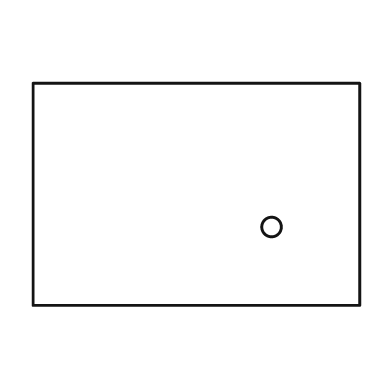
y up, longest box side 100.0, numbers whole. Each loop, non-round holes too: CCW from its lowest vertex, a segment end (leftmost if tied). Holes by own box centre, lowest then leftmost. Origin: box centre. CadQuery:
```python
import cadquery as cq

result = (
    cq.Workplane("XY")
    .moveTo(-50.0, -34.0)
    .lineTo(50.0, -34.0)
    .lineTo(50.0, 34.0)
    .lineTo(-50.0, 34.0)
    .close()
    .moveTo(23.0, -10.0)
    .circle(3.0)
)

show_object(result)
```